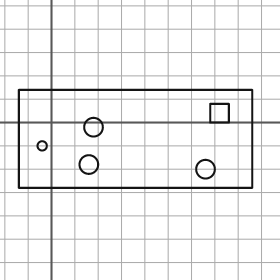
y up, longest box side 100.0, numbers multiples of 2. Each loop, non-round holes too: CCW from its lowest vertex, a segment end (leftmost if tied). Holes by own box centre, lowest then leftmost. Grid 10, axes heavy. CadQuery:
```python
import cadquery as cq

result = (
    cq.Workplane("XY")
    .moveTo(-14.0, -28.0)
    .lineTo(86.0, -28.0)
    .lineTo(86.0, 14.0)
    .lineTo(-14.0, 14.0)
    .close()
    .moveTo(66.0, -20.0)
    .circle(4.0)
    .moveTo(16.0, -18.0)
    .circle(4.0)
    .moveTo(-4.0, -10.0)
    .circle(2.0)
    .moveTo(18.0, -2.0)
    .circle(4.0)
    .moveTo(68.0, 0.0)
    .lineTo(76.0, 0.0)
    .lineTo(76.0, 8.0)
    .lineTo(68.0, 8.0)
    .close()
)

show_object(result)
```